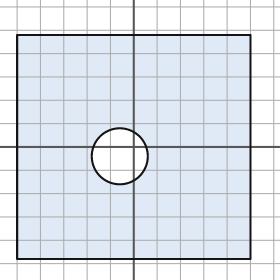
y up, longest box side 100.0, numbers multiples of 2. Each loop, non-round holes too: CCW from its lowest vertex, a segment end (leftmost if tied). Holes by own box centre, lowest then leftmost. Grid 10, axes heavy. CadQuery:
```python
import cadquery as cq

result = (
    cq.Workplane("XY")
    .moveTo(-50.0, -48.0)
    .lineTo(50.0, -48.0)
    .lineTo(50.0, 48.0)
    .lineTo(-50.0, 48.0)
    .close()
    .moveTo(-6.0, -4.0)
    .circle(12.0)
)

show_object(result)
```